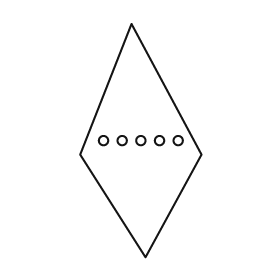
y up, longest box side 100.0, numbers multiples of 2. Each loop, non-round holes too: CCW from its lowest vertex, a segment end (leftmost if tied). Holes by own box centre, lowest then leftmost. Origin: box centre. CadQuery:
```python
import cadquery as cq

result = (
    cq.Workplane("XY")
    .moveTo(2.0, -50.0)
    .lineTo(26.0, -6.0)
    .lineTo(-4.0, 50.0)
    .lineTo(-26.0, -6.0)
    .close()
    .moveTo(-16.0, 0.0)
    .circle(2.0)
    .moveTo(-8.0, 0.0)
    .circle(2.0)
    .moveTo(0.0, 0.0)
    .circle(2.0)
    .moveTo(8.0, 0.0)
    .circle(2.0)
    .moveTo(16.0, 0.0)
    .circle(2.0)
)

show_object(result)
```